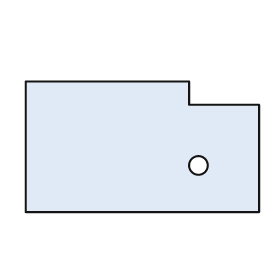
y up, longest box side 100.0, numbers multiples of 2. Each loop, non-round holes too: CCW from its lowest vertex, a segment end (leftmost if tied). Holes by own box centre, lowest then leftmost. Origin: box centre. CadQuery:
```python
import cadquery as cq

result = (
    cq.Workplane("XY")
    .moveTo(-50.0, -28.0)
    .lineTo(50.0, -28.0)
    .lineTo(50.0, 18.0)
    .lineTo(20.0, 18.0)
    .lineTo(20.0, 28.0)
    .lineTo(-50.0, 28.0)
    .close()
    .moveTo(24.0, -8.0)
    .circle(4.0)
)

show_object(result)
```